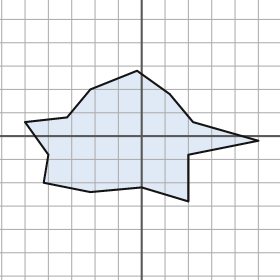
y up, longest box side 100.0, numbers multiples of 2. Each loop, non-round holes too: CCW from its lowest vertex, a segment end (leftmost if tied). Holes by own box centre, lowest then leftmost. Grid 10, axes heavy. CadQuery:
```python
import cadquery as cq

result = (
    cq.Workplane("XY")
    .moveTo(20.0, -28.0)
    .lineTo(20.0, -8.0)
    .lineTo(50.0, -2.0)
    .lineTo(22.0, 6.0)
    .lineTo(12.0, 18.0)
    .lineTo(-2.0, 28.0)
    .lineTo(-22.0, 20.0)
    .lineTo(-32.0, 8.0)
    .lineTo(-50.0, 6.0)
    .lineTo(-40.0, -8.0)
    .lineTo(-42.0, -20.0)
    .lineTo(-22.0, -24.0)
    .lineTo(0.0, -22.0)
    .close()
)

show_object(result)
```